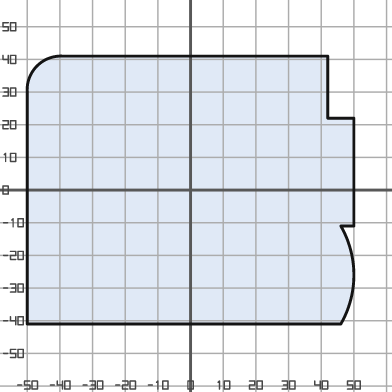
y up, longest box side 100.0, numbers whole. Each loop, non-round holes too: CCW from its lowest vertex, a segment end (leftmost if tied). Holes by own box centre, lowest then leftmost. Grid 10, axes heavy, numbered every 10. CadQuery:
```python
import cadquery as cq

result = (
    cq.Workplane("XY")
    .moveTo(-50.0, -41.0)
    .lineTo(46.0, -41.0)
    .threePointArc((50.0, -26.0), (46.0, -11.0))
    .lineTo(50.0, -11.0)
    .lineTo(50.0, 22.0)
    .lineTo(42.0, 22.0)
    .lineTo(42.0, 41.0)
    .lineTo(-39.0, 41.0)
    .threePointArc((-47.0, 38.0), (-50.0, 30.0))
    .close()
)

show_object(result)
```